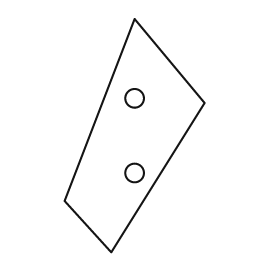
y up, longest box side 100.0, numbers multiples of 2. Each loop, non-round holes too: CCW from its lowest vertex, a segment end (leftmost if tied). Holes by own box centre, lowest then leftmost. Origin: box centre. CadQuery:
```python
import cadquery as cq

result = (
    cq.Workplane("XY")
    .moveTo(-10.0, -50.0)
    .lineTo(30.0, 14.0)
    .lineTo(0.0, 50.0)
    .lineTo(-30.0, -28.0)
    .close()
    .moveTo(0.0, -16.0)
    .circle(4.0)
    .moveTo(0.0, 16.0)
    .circle(4.0)
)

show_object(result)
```